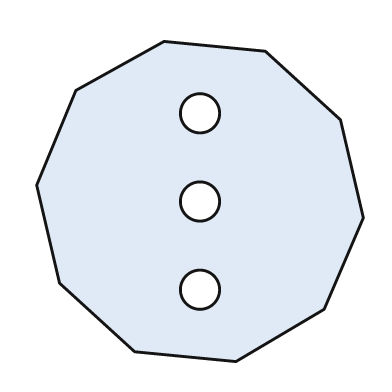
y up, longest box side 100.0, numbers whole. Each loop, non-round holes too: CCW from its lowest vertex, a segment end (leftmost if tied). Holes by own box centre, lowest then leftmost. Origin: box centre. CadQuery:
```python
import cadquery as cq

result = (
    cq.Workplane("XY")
    .moveTo(11.0, -49.0)
    .lineTo(38.0, -33.0)
    .lineTo(50.0, -5.0)
    .lineTo(43.0, 25.0)
    .lineTo(20.0, 46.0)
    .lineTo(-11.0, 49.0)
    .lineTo(-38.0, 34.0)
    .lineTo(-50.0, 5.0)
    .lineTo(-43.0, -25.0)
    .lineTo(-20.0, -46.0)
    .close()
    .moveTo(0.0, -27.0)
    .circle(6.0)
    .moveTo(0.0, 0.0)
    .circle(6.0)
    .moveTo(0.0, 27.0)
    .circle(6.0)
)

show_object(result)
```